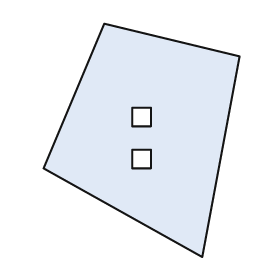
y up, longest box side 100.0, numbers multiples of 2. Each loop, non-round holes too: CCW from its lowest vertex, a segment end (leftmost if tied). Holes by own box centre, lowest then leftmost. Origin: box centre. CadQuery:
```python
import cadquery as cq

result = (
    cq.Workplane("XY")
    .moveTo(26.0, -50.0)
    .lineTo(42.0, 36.0)
    .lineTo(-16.0, 50.0)
    .lineTo(-42.0, -12.0)
    .close()
    .moveTo(-4.0, -12.0)
    .lineTo(4.0, -12.0)
    .lineTo(4.0, -4.0)
    .lineTo(-4.0, -4.0)
    .close()
    .moveTo(-4.0, 6.0)
    .lineTo(4.0, 6.0)
    .lineTo(4.0, 14.0)
    .lineTo(-4.0, 14.0)
    .close()
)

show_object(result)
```